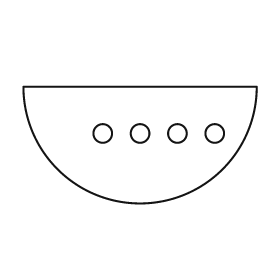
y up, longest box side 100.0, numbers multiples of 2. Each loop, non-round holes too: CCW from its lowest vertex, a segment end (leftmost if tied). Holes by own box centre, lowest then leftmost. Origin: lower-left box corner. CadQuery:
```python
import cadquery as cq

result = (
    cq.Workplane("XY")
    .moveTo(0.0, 50.0)
    .threePointArc((50.0, 0.0), (100.0, 50.0))
    .close()
    .moveTo(34.0, 30.0)
    .circle(4.0)
    .moveTo(50.0, 30.0)
    .circle(4.0)
    .moveTo(66.0, 30.0)
    .circle(4.0)
    .moveTo(82.0, 30.0)
    .circle(4.0)
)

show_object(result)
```